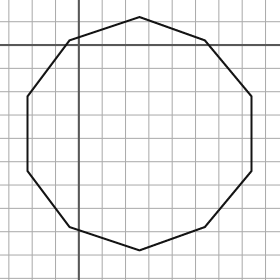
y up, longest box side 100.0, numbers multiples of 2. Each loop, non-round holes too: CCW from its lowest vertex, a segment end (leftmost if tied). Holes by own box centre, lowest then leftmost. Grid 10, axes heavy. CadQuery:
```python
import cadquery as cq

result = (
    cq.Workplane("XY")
    .moveTo(26.0, -88.0)
    .lineTo(54.0, -78.0)
    .lineTo(74.0, -54.0)
    .lineTo(74.0, -22.0)
    .lineTo(54.0, 2.0)
    .lineTo(26.0, 12.0)
    .lineTo(-4.0, 2.0)
    .lineTo(-22.0, -22.0)
    .lineTo(-22.0, -54.0)
    .lineTo(-4.0, -78.0)
    .close()
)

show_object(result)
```